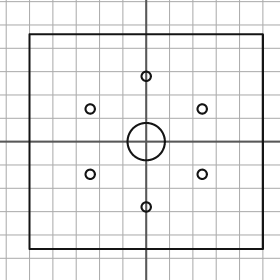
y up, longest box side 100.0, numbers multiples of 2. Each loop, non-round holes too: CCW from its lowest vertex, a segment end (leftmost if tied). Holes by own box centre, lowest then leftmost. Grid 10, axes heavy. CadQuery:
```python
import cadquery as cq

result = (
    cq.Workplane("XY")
    .moveTo(-50.0, -46.0)
    .lineTo(50.0, -46.0)
    .lineTo(50.0, 46.0)
    .lineTo(-50.0, 46.0)
    .close()
    .moveTo(0.0, -28.0)
    .circle(2.0)
    .moveTo(-24.0, -14.0)
    .circle(2.0)
    .moveTo(24.0, -14.0)
    .circle(2.0)
    .moveTo(0.0, 0.0)
    .circle(8.0)
    .moveTo(-24.0, 14.0)
    .circle(2.0)
    .moveTo(24.0, 14.0)
    .circle(2.0)
    .moveTo(0.0, 28.0)
    .circle(2.0)
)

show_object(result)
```